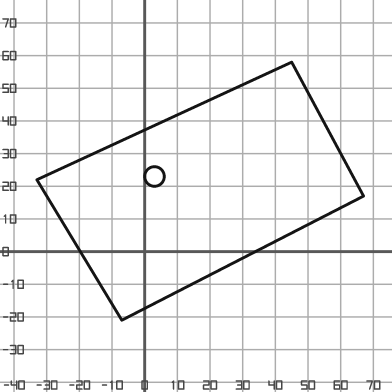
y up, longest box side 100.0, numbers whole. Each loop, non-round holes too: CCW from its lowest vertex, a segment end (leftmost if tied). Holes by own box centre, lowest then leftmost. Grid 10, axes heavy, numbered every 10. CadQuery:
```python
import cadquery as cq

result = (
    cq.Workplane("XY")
    .moveTo(-7.0, -21.0)
    .lineTo(67.0, 17.0)
    .lineTo(45.0, 58.0)
    .lineTo(-33.0, 22.0)
    .close()
    .moveTo(3.0, 23.0)
    .circle(3.0)
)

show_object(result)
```